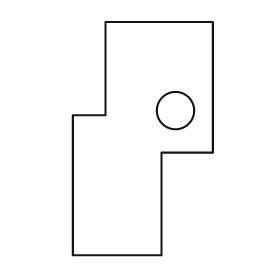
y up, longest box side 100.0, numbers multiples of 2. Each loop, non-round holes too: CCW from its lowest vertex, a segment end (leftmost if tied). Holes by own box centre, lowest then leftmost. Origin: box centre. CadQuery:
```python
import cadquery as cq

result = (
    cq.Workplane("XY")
    .moveTo(-30.0, -50.0)
    .lineTo(8.0, -50.0)
    .lineTo(8.0, -6.0)
    .lineTo(30.0, -6.0)
    .lineTo(30.0, 50.0)
    .lineTo(-16.0, 50.0)
    .lineTo(-16.0, 10.0)
    .lineTo(-30.0, 10.0)
    .close()
    .moveTo(14.0, 12.0)
    .circle(8.0)
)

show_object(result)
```